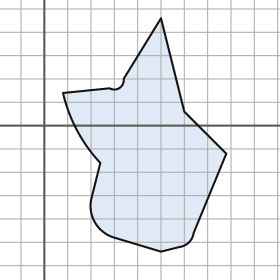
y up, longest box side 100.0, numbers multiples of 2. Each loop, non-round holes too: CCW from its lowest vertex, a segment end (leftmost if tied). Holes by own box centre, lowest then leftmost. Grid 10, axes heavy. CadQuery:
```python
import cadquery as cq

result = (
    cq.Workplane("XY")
    .moveTo(50.0, -54.0)
    .lineTo(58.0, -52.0)
    .threePointArc((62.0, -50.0), (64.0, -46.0))
    .lineTo(78.0, -12.0)
    .lineTo(60.0, 6.0)
    .lineTo(50.0, 46.0)
    .lineTo(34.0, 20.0)
    .threePointArc((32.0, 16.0), (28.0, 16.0))
    .lineTo(8.0, 14.0)
    .threePointArc((14.0, -2.0), (24.0, -16.0))
    .lineTo(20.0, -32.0)
    .threePointArc((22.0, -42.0), (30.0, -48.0))
    .close()
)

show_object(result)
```